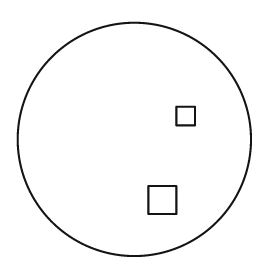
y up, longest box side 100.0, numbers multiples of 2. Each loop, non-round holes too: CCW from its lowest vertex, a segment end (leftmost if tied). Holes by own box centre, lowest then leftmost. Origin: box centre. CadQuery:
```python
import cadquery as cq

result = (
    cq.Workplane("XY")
    .moveTo(0.0, 0.0)
    .circle(50.0)
    .moveTo(6.0, -32.0)
    .lineTo(18.0, -32.0)
    .lineTo(18.0, -20.0)
    .lineTo(6.0, -20.0)
    .close()
    .moveTo(18.0, 6.0)
    .lineTo(26.0, 6.0)
    .lineTo(26.0, 14.0)
    .lineTo(18.0, 14.0)
    .close()
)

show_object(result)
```